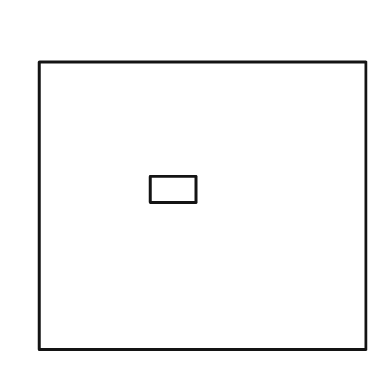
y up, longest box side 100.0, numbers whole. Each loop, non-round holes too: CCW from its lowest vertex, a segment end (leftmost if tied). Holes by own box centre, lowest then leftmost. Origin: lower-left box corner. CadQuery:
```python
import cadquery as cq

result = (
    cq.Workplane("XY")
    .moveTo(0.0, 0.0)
    .lineTo(100.0, 0.0)
    .lineTo(100.0, 88.0)
    .lineTo(0.0, 88.0)
    .close()
    .moveTo(34.0, 45.0)
    .lineTo(48.0, 45.0)
    .lineTo(48.0, 53.0)
    .lineTo(34.0, 53.0)
    .close()
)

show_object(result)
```